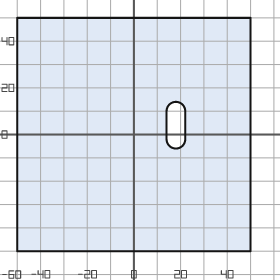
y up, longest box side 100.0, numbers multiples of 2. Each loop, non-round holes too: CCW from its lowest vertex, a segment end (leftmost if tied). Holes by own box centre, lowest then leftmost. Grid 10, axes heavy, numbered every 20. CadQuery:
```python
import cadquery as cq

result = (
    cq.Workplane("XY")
    .moveTo(-50.0, -50.0)
    .lineTo(50.0, -50.0)
    .lineTo(50.0, 50.0)
    .lineTo(-50.0, 50.0)
    .close()
    .moveTo(14.0, -2.0)
    .threePointArc((18.0, -6.0), (22.0, -2.0))
    .lineTo(22.0, 10.0)
    .threePointArc((18.0, 14.0), (14.0, 10.0))
    .close()
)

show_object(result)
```